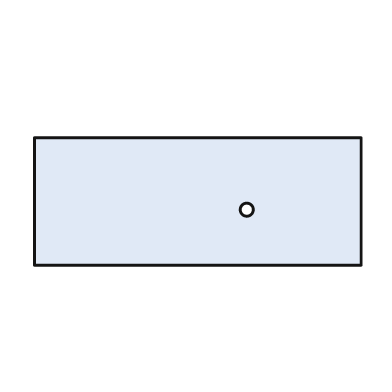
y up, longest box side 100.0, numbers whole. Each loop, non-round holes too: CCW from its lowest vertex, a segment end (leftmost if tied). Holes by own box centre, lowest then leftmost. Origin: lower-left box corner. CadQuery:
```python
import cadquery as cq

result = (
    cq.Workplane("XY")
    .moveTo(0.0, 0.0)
    .lineTo(100.0, 0.0)
    .lineTo(100.0, 39.0)
    .lineTo(0.0, 39.0)
    .close()
    .moveTo(65.0, 17.0)
    .circle(2.0)
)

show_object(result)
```